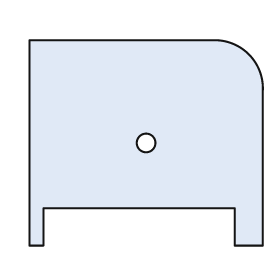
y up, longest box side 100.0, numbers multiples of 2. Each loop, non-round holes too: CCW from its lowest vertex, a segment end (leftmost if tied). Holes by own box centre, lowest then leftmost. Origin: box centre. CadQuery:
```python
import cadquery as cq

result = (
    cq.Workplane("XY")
    .moveTo(-50.0, -44.0)
    .lineTo(-44.0, -44.0)
    .lineTo(-44.0, -28.0)
    .lineTo(38.0, -28.0)
    .lineTo(38.0, -44.0)
    .lineTo(50.0, -44.0)
    .lineTo(50.0, 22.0)
    .threePointArc((44.0, 38.0), (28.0, 44.0))
    .lineTo(-50.0, 44.0)
    .close()
    .moveTo(0.0, 0.0)
    .circle(4.0)
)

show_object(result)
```